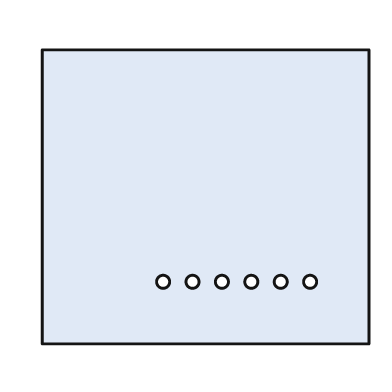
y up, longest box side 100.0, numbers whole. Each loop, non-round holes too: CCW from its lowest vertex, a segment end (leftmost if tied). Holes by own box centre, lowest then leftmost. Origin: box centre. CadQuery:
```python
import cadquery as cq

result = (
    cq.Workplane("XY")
    .moveTo(-50.0, -45.0)
    .lineTo(50.0, -45.0)
    .lineTo(50.0, 45.0)
    .lineTo(-50.0, 45.0)
    .close()
    .moveTo(-13.0, -26.0)
    .circle(2.0)
    .moveTo(-4.0, -26.0)
    .circle(2.0)
    .moveTo(5.0, -26.0)
    .circle(2.0)
    .moveTo(14.0, -26.0)
    .circle(2.0)
    .moveTo(23.0, -26.0)
    .circle(2.0)
    .moveTo(32.0, -26.0)
    .circle(2.0)
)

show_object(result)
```